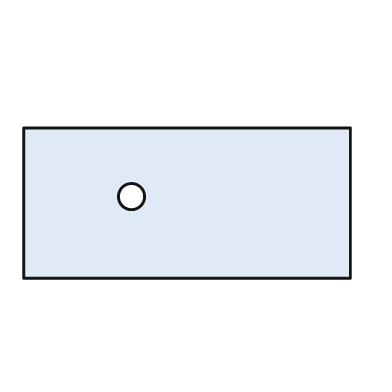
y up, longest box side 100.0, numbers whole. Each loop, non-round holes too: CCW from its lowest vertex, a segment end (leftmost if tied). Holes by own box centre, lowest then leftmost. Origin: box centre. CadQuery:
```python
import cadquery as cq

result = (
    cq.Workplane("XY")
    .moveTo(-50.0, -23.0)
    .lineTo(50.0, -23.0)
    .lineTo(50.0, 23.0)
    .lineTo(-50.0, 23.0)
    .close()
    .moveTo(-17.0, 2.0)
    .circle(4.0)
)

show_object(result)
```